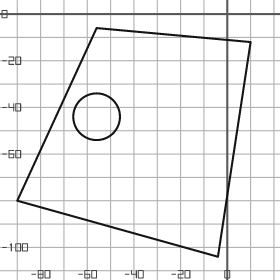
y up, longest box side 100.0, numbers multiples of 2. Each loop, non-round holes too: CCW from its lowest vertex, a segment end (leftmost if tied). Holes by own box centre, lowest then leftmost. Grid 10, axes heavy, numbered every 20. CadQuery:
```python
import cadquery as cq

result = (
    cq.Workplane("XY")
    .moveTo(-4.0, -104.0)
    .lineTo(10.0, -12.0)
    .lineTo(-56.0, -6.0)
    .lineTo(-90.0, -80.0)
    .close()
    .moveTo(-56.0, -44.0)
    .circle(10.0)
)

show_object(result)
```